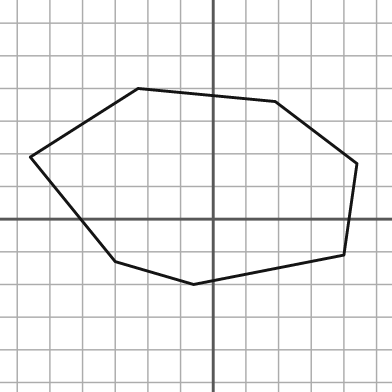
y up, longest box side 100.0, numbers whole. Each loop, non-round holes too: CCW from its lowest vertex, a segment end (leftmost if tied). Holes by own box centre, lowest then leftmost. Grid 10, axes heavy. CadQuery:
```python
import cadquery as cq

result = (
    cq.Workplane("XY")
    .moveTo(-6.0, -20.0)
    .lineTo(40.0, -11.0)
    .lineTo(44.0, 17.0)
    .lineTo(19.0, 36.0)
    .lineTo(-23.0, 40.0)
    .lineTo(-56.0, 19.0)
    .lineTo(-30.0, -13.0)
    .close()
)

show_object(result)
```